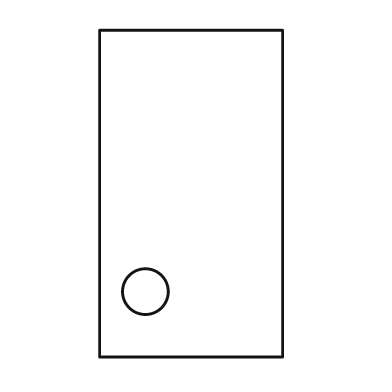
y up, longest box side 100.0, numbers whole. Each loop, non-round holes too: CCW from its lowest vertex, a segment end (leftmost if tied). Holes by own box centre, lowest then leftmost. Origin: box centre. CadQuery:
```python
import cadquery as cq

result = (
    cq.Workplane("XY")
    .moveTo(-28.0, -50.0)
    .lineTo(28.0, -50.0)
    .lineTo(28.0, 50.0)
    .lineTo(-28.0, 50.0)
    .close()
    .moveTo(-14.0, -30.0)
    .circle(7.0)
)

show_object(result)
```